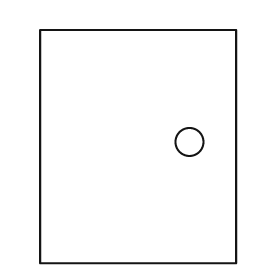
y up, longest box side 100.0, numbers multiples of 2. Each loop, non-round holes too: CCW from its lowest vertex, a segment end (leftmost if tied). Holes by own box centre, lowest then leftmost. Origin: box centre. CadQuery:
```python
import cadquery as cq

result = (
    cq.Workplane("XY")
    .moveTo(-42.0, -50.0)
    .lineTo(42.0, -50.0)
    .lineTo(42.0, 50.0)
    .lineTo(-42.0, 50.0)
    .close()
    .moveTo(22.0, 2.0)
    .circle(6.0)
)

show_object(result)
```